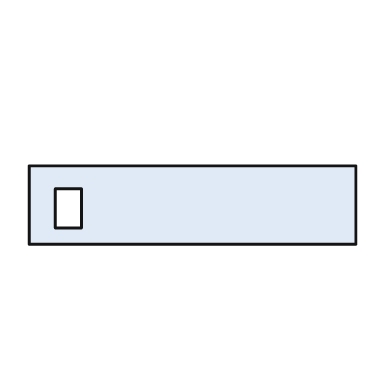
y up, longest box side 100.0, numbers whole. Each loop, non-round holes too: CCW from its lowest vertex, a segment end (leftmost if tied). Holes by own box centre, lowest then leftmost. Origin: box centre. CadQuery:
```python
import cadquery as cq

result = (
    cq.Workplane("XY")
    .moveTo(-50.0, -12.0)
    .lineTo(50.0, -12.0)
    .lineTo(50.0, 12.0)
    .lineTo(-50.0, 12.0)
    .close()
    .moveTo(-42.0, -7.0)
    .lineTo(-34.0, -7.0)
    .lineTo(-34.0, 5.0)
    .lineTo(-42.0, 5.0)
    .close()
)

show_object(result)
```